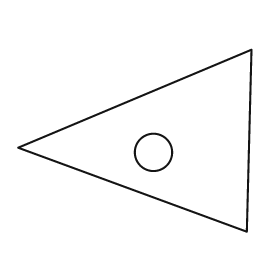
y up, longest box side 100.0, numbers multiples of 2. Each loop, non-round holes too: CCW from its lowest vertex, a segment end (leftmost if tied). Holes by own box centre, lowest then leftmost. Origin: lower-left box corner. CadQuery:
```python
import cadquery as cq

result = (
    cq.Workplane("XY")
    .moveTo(98.0, 0.0)
    .lineTo(100.0, 78.0)
    .lineTo(0.0, 36.0)
    .close()
    .moveTo(58.0, 34.0)
    .circle(8.0)
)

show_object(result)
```